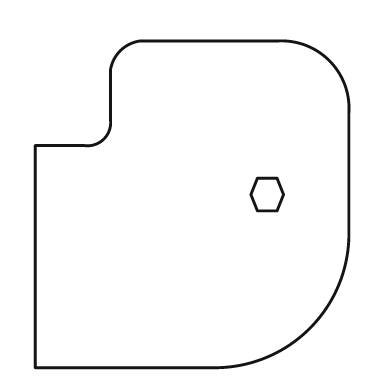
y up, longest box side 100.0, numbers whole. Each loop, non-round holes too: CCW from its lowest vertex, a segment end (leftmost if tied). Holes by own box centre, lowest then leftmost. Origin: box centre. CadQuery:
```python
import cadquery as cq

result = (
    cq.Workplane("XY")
    .moveTo(-48.0, -50.0)
    .lineTo(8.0, -50.0)
    .threePointArc((36.0, -38.0), (48.0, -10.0))
    .lineTo(48.0, 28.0)
    .threePointArc((42.0, 44.0), (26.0, 50.0))
    .lineTo(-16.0, 50.0)
    .threePointArc((-22.0, 47.0), (-25.0, 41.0))
    .lineTo(-25.0, 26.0)
    .threePointArc((-27.0, 20.0), (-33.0, 18.0))
    .lineTo(-48.0, 18.0)
    .close()
    .moveTo(20.0, -2.0)
    .lineTo(26.0, -2.0)
    .lineTo(28.0, 3.0)
    .lineTo(26.0, 8.0)
    .lineTo(20.0, 8.0)
    .lineTo(18.0, 3.0)
    .close()
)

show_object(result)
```